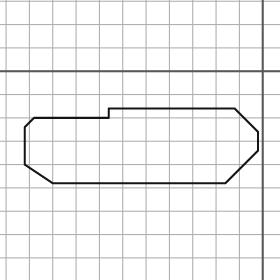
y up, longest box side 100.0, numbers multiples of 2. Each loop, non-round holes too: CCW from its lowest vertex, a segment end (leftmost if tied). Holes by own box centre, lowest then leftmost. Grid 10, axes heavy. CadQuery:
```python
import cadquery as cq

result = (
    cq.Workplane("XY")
    .moveTo(-90.0, -48.0)
    .lineTo(-16.0, -48.0)
    .lineTo(-2.0, -34.0)
    .lineTo(-2.0, -26.0)
    .lineTo(-12.0, -16.0)
    .lineTo(-66.0, -16.0)
    .lineTo(-66.0, -20.0)
    .lineTo(-98.0, -20.0)
    .lineTo(-102.0, -24.0)
    .lineTo(-102.0, -40.0)
    .close()
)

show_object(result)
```